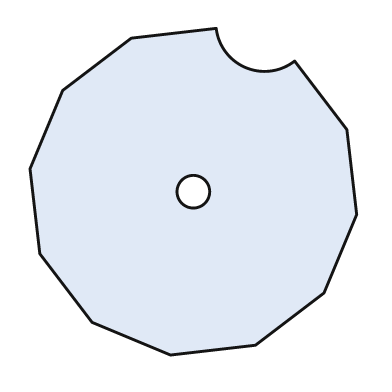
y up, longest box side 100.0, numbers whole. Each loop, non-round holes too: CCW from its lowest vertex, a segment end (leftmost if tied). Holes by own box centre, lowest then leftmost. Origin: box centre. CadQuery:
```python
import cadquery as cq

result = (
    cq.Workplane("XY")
    .moveTo(-7.0, -50.0)
    .lineTo(19.0, -47.0)
    .lineTo(40.0, -31.0)
    .lineTo(50.0, -7.0)
    .lineTo(47.0, 19.0)
    .lineTo(31.0, 40.0)
    .threePointArc((16.0, 38.0), (7.0, 50.0))
    .lineTo(-19.0, 47.0)
    .lineTo(-40.0, 31.0)
    .lineTo(-50.0, 7.0)
    .lineTo(-47.0, -19.0)
    .lineTo(-31.0, -40.0)
    .close()
    .moveTo(0.0, 0.0)
    .circle(5.0)
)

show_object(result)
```